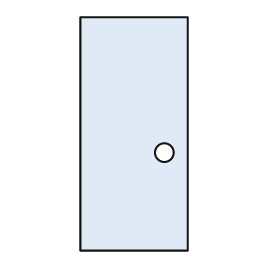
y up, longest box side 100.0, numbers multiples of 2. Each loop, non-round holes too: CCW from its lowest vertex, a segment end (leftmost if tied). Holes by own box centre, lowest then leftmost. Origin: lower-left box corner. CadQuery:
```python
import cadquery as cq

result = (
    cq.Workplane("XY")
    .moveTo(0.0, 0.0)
    .lineTo(46.0, 0.0)
    .lineTo(46.0, 100.0)
    .lineTo(0.0, 100.0)
    .close()
    .moveTo(36.0, 42.0)
    .circle(4.0)
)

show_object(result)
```